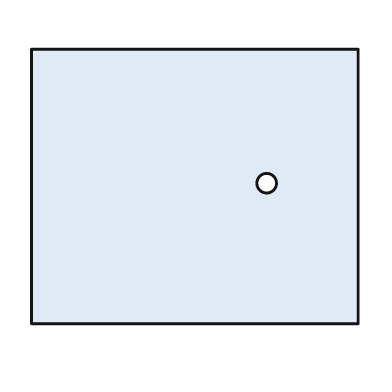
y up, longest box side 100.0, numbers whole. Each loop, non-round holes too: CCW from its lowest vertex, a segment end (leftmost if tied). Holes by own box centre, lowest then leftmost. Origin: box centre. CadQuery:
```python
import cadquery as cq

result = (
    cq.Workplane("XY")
    .moveTo(-50.0, -42.0)
    .lineTo(50.0, -42.0)
    .lineTo(50.0, 42.0)
    .lineTo(-50.0, 42.0)
    .close()
    .moveTo(22.0, 1.0)
    .circle(3.0)
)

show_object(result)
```